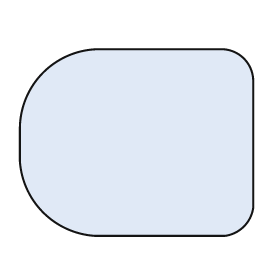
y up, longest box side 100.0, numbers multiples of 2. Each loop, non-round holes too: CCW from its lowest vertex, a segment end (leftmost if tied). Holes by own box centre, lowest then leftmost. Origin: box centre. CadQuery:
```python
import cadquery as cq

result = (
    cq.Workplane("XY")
    .moveTo(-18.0, -40.0)
    .lineTo(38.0, -40.0)
    .threePointArc((46.0, -36.0), (50.0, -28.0))
    .lineTo(50.0, 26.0)
    .threePointArc((46.0, 36.0), (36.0, 40.0))
    .lineTo(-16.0, 40.0)
    .threePointArc((-40.0, 30.0), (-50.0, 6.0))
    .lineTo(-50.0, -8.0)
    .threePointArc((-40.0, -30.0), (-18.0, -40.0))
    .close()
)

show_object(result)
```